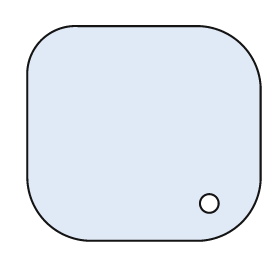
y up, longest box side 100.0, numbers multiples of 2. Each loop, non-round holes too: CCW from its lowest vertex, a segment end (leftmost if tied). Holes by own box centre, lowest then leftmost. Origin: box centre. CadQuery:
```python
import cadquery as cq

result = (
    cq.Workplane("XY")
    .moveTo(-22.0, -46.0)
    .lineTo(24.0, -46.0)
    .threePointArc((42.0, -38.0), (50.0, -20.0))
    .lineTo(50.0, 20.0)
    .threePointArc((42.0, 38.0), (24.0, 46.0))
    .lineTo(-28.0, 46.0)
    .threePointArc((-44.0, 40.0), (-50.0, 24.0))
    .lineTo(-50.0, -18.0)
    .threePointArc((-42.0, -38.0), (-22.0, -46.0))
    .close()
    .moveTo(28.0, -30.0)
    .circle(4.0)
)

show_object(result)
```